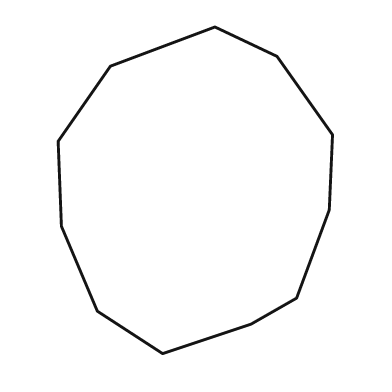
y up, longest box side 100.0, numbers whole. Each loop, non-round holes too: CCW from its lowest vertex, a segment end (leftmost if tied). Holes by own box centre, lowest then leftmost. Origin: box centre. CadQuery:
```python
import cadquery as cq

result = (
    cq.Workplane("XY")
    .moveTo(-10.0, -50.0)
    .lineTo(17.0, -41.0)
    .lineTo(31.0, -33.0)
    .lineTo(41.0, -6.0)
    .lineTo(42.0, 17.0)
    .lineTo(25.0, 41.0)
    .lineTo(6.0, 50.0)
    .lineTo(-26.0, 38.0)
    .lineTo(-42.0, 15.0)
    .lineTo(-41.0, -11.0)
    .lineTo(-30.0, -37.0)
    .close()
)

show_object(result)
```